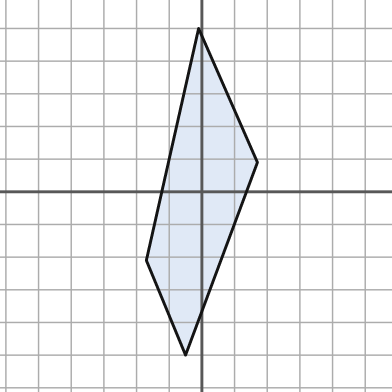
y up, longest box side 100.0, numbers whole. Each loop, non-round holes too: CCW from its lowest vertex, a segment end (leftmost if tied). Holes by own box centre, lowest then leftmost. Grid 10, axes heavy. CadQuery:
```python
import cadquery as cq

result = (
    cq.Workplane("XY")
    .moveTo(-5.0, -50.0)
    .lineTo(17.0, 9.0)
    .lineTo(-1.0, 50.0)
    .lineTo(-17.0, -21.0)
    .close()
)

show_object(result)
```